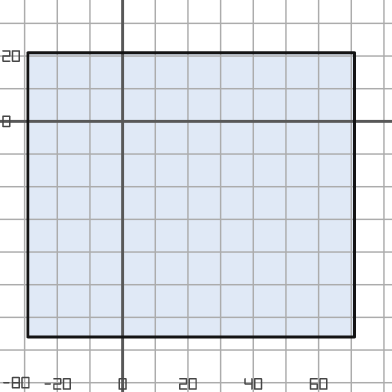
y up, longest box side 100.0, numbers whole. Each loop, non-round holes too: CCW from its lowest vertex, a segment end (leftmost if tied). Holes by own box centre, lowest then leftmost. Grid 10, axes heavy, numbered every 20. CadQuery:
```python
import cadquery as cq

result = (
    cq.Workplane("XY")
    .moveTo(-29.0, -66.0)
    .lineTo(71.0, -66.0)
    .lineTo(71.0, 21.0)
    .lineTo(-29.0, 21.0)
    .close()
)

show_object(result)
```